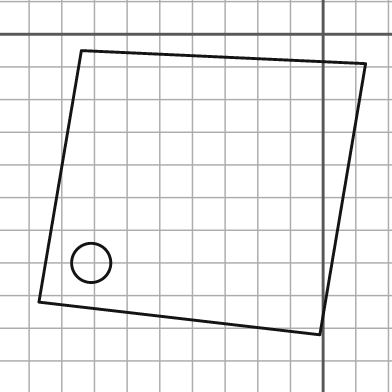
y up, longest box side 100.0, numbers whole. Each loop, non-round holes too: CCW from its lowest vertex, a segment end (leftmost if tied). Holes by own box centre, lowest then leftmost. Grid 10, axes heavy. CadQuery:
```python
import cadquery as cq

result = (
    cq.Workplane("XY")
    .moveTo(-1.0, -92.0)
    .lineTo(13.0, -9.0)
    .lineTo(-74.0, -5.0)
    .lineTo(-87.0, -82.0)
    .close()
    .moveTo(-71.0, -70.0)
    .circle(6.0)
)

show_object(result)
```